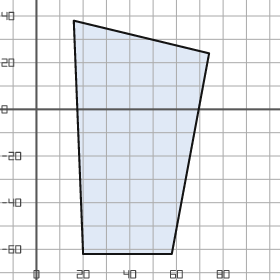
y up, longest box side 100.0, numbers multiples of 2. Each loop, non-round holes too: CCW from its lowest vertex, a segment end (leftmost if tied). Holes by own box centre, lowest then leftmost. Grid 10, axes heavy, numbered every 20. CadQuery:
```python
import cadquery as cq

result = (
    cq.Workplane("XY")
    .moveTo(20.0, -62.0)
    .lineTo(58.0, -62.0)
    .lineTo(74.0, 24.0)
    .lineTo(16.0, 38.0)
    .close()
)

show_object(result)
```